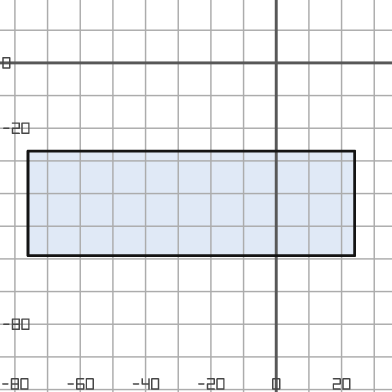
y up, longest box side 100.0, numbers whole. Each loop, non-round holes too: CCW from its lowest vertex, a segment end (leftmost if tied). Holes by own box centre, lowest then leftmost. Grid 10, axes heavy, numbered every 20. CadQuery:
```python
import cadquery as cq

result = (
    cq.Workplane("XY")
    .moveTo(-76.0, -59.0)
    .lineTo(24.0, -59.0)
    .lineTo(24.0, -27.0)
    .lineTo(-76.0, -27.0)
    .close()
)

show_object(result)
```